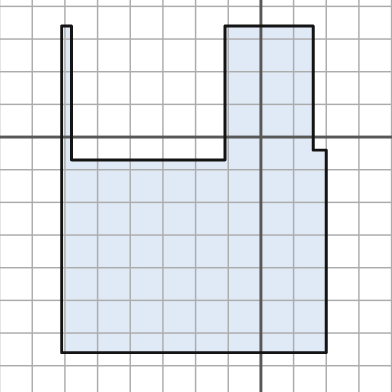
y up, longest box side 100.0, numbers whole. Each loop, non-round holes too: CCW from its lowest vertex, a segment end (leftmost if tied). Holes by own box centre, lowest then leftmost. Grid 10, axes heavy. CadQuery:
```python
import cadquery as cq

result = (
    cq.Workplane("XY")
    .moveTo(-61.0, -66.0)
    .lineTo(20.0, -66.0)
    .lineTo(20.0, -4.0)
    .lineTo(16.0, -4.0)
    .lineTo(16.0, 34.0)
    .lineTo(-11.0, 34.0)
    .lineTo(-11.0, -7.0)
    .lineTo(-58.0, -7.0)
    .lineTo(-58.0, 34.0)
    .lineTo(-61.0, 34.0)
    .close()
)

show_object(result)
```